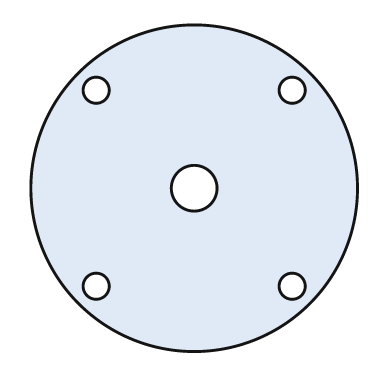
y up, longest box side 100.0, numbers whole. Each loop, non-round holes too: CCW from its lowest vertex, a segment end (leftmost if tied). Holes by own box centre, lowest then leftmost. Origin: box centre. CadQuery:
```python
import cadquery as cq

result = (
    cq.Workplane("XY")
    .moveTo(0.0, 0.0)
    .circle(50.0)
    .moveTo(-30.0, -30.0)
    .circle(4.0)
    .moveTo(30.0, -30.0)
    .circle(4.0)
    .moveTo(0.0, 0.0)
    .circle(7.0)
    .moveTo(-30.0, 30.0)
    .circle(4.0)
    .moveTo(30.0, 30.0)
    .circle(4.0)
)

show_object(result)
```